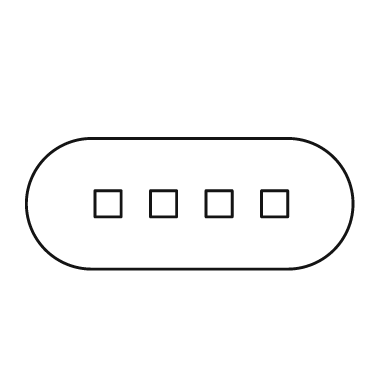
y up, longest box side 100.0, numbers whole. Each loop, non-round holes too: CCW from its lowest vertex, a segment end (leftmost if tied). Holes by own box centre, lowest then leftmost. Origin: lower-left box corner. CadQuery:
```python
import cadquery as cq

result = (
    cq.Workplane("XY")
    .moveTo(20.0, 0.0)
    .lineTo(80.0, 0.0)
    .threePointArc((100.0, 20.0), (80.0, 40.0))
    .lineTo(20.0, 40.0)
    .threePointArc((0.0, 20.0), (20.0, 0.0))
    .close()
    .moveTo(21.0, 16.0)
    .lineTo(29.0, 16.0)
    .lineTo(29.0, 24.0)
    .lineTo(21.0, 24.0)
    .close()
    .moveTo(38.0, 16.0)
    .lineTo(46.0, 16.0)
    .lineTo(46.0, 24.0)
    .lineTo(38.0, 24.0)
    .close()
    .moveTo(55.0, 16.0)
    .lineTo(63.0, 16.0)
    .lineTo(63.0, 24.0)
    .lineTo(55.0, 24.0)
    .close()
    .moveTo(72.0, 16.0)
    .lineTo(80.0, 16.0)
    .lineTo(80.0, 24.0)
    .lineTo(72.0, 24.0)
    .close()
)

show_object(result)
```